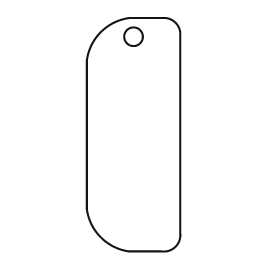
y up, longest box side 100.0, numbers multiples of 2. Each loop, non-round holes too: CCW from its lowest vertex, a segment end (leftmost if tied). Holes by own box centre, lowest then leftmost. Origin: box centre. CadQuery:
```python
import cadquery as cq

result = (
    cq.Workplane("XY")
    .moveTo(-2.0, -50.0)
    .lineTo(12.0, -50.0)
    .threePointArc((18.0, -48.0), (20.0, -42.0))
    .lineTo(20.0, 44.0)
    .threePointArc((18.0, 48.0), (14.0, 50.0))
    .lineTo(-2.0, 50.0)
    .threePointArc((-14.0, 44.0), (-20.0, 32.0))
    .lineTo(-20.0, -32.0)
    .threePointArc((-14.0, -44.0), (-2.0, -50.0))
    .close()
    .moveTo(0.0, 42.0)
    .circle(4.0)
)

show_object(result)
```